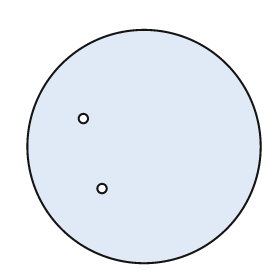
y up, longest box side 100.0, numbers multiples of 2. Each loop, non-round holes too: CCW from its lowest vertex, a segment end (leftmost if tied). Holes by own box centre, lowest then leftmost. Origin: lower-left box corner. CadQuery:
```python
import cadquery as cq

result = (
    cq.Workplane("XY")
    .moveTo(50.0, 50.0)
    .circle(50.0)
    .moveTo(32.0, 32.0)
    .circle(2.0)
    .moveTo(24.0, 62.0)
    .circle(2.0)
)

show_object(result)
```